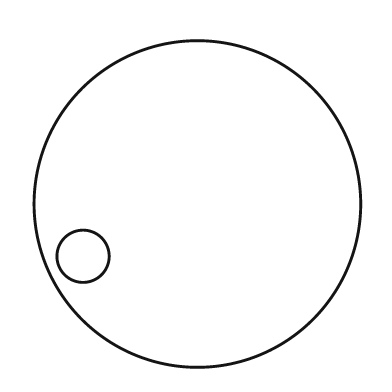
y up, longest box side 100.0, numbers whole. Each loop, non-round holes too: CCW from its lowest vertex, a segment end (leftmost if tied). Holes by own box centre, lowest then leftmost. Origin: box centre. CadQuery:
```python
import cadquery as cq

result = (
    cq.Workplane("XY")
    .moveTo(0.0, 0.0)
    .circle(50.0)
    .moveTo(-35.0, -16.0)
    .circle(8.0)
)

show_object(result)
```